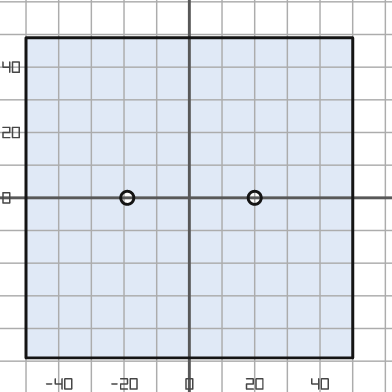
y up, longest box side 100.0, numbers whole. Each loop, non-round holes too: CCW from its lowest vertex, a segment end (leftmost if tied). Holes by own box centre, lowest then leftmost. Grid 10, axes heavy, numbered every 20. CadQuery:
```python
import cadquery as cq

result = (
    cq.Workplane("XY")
    .moveTo(-50.0, -49.0)
    .lineTo(50.0, -49.0)
    .lineTo(50.0, 49.0)
    .lineTo(-50.0, 49.0)
    .close()
    .moveTo(-19.0, 0.0)
    .circle(2.0)
    .moveTo(20.0, 0.0)
    .circle(2.0)
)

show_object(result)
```